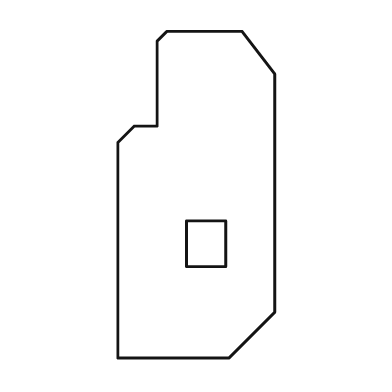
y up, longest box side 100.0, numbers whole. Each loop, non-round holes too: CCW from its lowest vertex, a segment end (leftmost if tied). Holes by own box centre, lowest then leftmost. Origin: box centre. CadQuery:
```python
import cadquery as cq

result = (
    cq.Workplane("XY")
    .moveTo(-24.0, -50.0)
    .lineTo(10.0, -50.0)
    .lineTo(24.0, -36.0)
    .lineTo(24.0, 37.0)
    .lineTo(14.0, 50.0)
    .lineTo(-9.0, 50.0)
    .lineTo(-12.0, 47.0)
    .lineTo(-12.0, 21.0)
    .lineTo(-19.0, 21.0)
    .lineTo(-24.0, 16.0)
    .close()
    .moveTo(-3.0, -22.0)
    .lineTo(9.0, -22.0)
    .lineTo(9.0, -8.0)
    .lineTo(-3.0, -8.0)
    .close()
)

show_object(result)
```